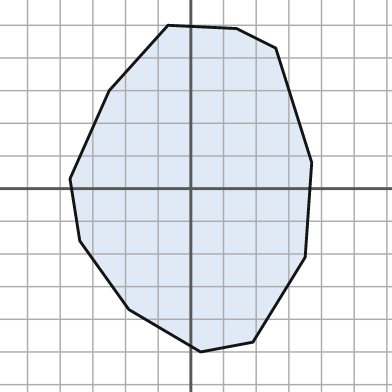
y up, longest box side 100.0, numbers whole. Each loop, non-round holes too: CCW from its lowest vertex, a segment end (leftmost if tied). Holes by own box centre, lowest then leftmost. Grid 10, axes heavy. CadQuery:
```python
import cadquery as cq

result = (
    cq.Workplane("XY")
    .moveTo(3.0, -50.0)
    .lineTo(19.0, -47.0)
    .lineTo(35.0, -21.0)
    .lineTo(37.0, 8.0)
    .lineTo(26.0, 43.0)
    .lineTo(14.0, 49.0)
    .lineTo(-7.0, 50.0)
    .lineTo(-25.0, 30.0)
    .lineTo(-37.0, 3.0)
    .lineTo(-34.0, -16.0)
    .lineTo(-19.0, -37.0)
    .close()
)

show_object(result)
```